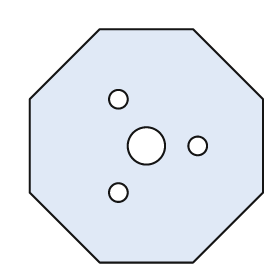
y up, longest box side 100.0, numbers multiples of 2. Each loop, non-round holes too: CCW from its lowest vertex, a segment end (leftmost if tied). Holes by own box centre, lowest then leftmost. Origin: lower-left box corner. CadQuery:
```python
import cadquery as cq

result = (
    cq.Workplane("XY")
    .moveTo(30.0, 0.0)
    .lineTo(70.0, 0.0)
    .lineTo(100.0, 30.0)
    .lineTo(100.0, 70.0)
    .lineTo(70.0, 100.0)
    .lineTo(30.0, 100.0)
    .lineTo(0.0, 70.0)
    .lineTo(0.0, 30.0)
    .close()
    .moveTo(38.0, 30.0)
    .circle(4.0)
    .moveTo(50.0, 50.0)
    .circle(8.0)
    .moveTo(72.0, 50.0)
    .circle(4.0)
    .moveTo(38.0, 70.0)
    .circle(4.0)
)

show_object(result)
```